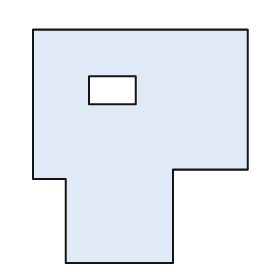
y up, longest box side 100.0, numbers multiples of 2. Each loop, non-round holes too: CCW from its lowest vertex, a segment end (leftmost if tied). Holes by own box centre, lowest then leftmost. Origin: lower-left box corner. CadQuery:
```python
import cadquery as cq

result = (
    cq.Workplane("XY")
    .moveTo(14.0, 0.0)
    .lineTo(60.0, 0.0)
    .lineTo(60.0, 40.0)
    .lineTo(92.0, 40.0)
    .lineTo(92.0, 100.0)
    .lineTo(0.0, 100.0)
    .lineTo(0.0, 36.0)
    .lineTo(14.0, 36.0)
    .close()
    .moveTo(24.0, 68.0)
    .lineTo(44.0, 68.0)
    .lineTo(44.0, 80.0)
    .lineTo(24.0, 80.0)
    .close()
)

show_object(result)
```